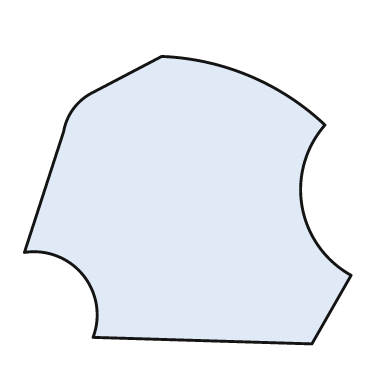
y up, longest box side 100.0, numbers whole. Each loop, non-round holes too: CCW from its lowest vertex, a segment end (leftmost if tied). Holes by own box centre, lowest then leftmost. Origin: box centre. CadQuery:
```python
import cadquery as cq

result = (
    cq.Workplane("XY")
    .moveTo(38.0, -44.0)
    .lineTo(50.0, -23.0)
    .threePointArc((35.0, -2.0), (42.0, 23.0))
    .threePointArc((19.0, 38.0), (-8.0, 44.0))
    .lineTo(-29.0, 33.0)
    .threePointArc((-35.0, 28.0), (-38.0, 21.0))
    .lineTo(-50.0, -16.0)
    .threePointArc((-32.0, -23.0), (-29.0, -42.0))
    .close()
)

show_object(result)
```